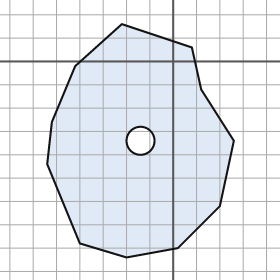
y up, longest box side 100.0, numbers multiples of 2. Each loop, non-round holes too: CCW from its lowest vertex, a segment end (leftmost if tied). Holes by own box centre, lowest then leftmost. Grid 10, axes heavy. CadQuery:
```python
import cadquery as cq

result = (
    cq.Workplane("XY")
    .moveTo(-20.0, -84.0)
    .lineTo(2.0, -80.0)
    .lineTo(20.0, -62.0)
    .lineTo(26.0, -34.0)
    .lineTo(12.0, -12.0)
    .lineTo(8.0, 6.0)
    .lineTo(-22.0, 16.0)
    .lineTo(-42.0, -2.0)
    .lineTo(-52.0, -26.0)
    .lineTo(-54.0, -44.0)
    .lineTo(-40.0, -78.0)
    .close()
    .moveTo(-14.0, -34.0)
    .circle(6.0)
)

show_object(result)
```